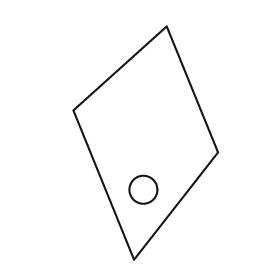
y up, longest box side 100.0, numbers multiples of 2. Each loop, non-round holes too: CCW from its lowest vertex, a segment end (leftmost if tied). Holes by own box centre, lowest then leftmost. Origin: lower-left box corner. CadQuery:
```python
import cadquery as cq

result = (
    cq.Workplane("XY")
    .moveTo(26.0, 0.0)
    .lineTo(62.0, 46.0)
    .lineTo(40.0, 100.0)
    .lineTo(0.0, 64.0)
    .close()
    .moveTo(30.0, 30.0)
    .circle(6.0)
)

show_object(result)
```